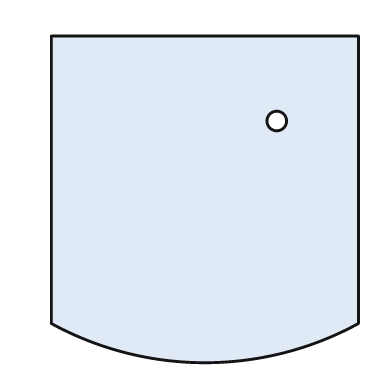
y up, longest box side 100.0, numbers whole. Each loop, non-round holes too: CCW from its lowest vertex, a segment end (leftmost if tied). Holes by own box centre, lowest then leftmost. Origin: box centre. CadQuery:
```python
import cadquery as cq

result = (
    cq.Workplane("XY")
    .moveTo(-47.0, -38.0)
    .threePointArc((0.0, -50.0), (47.0, -38.0))
    .lineTo(47.0, 50.0)
    .lineTo(-47.0, 50.0)
    .close()
    .moveTo(22.0, 24.0)
    .circle(3.0)
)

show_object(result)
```